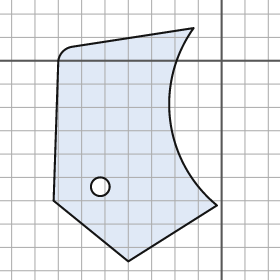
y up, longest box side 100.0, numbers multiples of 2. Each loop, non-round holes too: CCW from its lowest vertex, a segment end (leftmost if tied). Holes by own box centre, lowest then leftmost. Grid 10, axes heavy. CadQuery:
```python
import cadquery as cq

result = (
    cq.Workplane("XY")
    .moveTo(-40.0, -86.0)
    .lineTo(-2.0, -62.0)
    .threePointArc((-22.0, -26.0), (-12.0, 14.0))
    .lineTo(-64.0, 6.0)
    .threePointArc((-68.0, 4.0), (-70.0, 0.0))
    .lineTo(-72.0, -60.0)
    .close()
    .moveTo(-52.0, -54.0)
    .circle(4.0)
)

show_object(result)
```